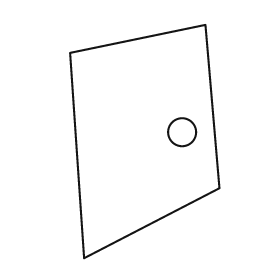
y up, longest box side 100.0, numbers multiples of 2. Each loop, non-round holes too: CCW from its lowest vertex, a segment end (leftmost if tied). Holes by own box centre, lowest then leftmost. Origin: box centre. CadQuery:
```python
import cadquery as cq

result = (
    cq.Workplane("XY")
    .moveTo(-26.0, -50.0)
    .lineTo(32.0, -20.0)
    .lineTo(26.0, 50.0)
    .lineTo(-32.0, 38.0)
    .close()
    .moveTo(16.0, 4.0)
    .circle(6.0)
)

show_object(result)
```